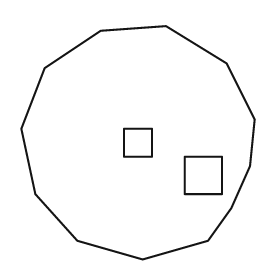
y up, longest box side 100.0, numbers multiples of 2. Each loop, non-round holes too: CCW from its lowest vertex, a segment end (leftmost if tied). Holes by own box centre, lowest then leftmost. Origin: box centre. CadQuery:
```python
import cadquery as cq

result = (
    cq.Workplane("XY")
    .moveTo(2.0, -50.0)
    .lineTo(30.0, -42.0)
    .lineTo(40.0, -28.0)
    .lineTo(48.0, -10.0)
    .lineTo(50.0, 10.0)
    .lineTo(38.0, 34.0)
    .lineTo(12.0, 50.0)
    .lineTo(-16.0, 48.0)
    .lineTo(-40.0, 32.0)
    .lineTo(-50.0, 6.0)
    .lineTo(-44.0, -22.0)
    .lineTo(-26.0, -42.0)
    .close()
    .moveTo(20.0, -22.0)
    .lineTo(36.0, -22.0)
    .lineTo(36.0, -6.0)
    .lineTo(20.0, -6.0)
    .close()
    .moveTo(-6.0, -6.0)
    .lineTo(6.0, -6.0)
    .lineTo(6.0, 6.0)
    .lineTo(-6.0, 6.0)
    .close()
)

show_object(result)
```